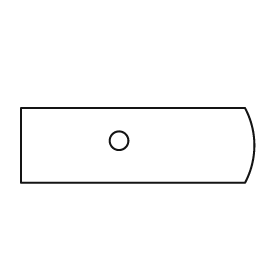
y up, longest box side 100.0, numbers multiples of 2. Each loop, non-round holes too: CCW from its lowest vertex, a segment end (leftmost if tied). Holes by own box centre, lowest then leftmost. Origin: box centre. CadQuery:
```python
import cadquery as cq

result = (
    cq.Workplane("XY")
    .moveTo(-50.0, -16.0)
    .lineTo(46.0, -16.0)
    .threePointArc((50.0, 0.0), (46.0, 16.0))
    .lineTo(-50.0, 16.0)
    .close()
    .moveTo(-8.0, 2.0)
    .circle(4.0)
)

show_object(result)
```